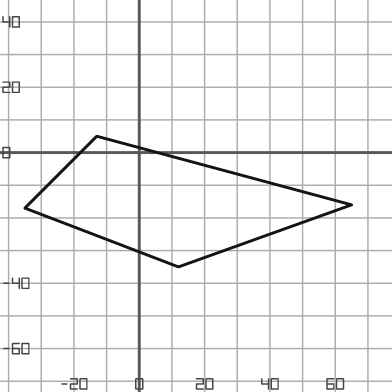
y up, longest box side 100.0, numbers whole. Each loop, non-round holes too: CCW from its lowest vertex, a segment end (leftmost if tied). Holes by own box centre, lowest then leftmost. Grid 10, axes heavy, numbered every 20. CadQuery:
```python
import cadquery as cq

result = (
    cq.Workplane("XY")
    .moveTo(12.0, -35.0)
    .lineTo(65.0, -16.0)
    .lineTo(-13.0, 5.0)
    .lineTo(-35.0, -17.0)
    .close()
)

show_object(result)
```